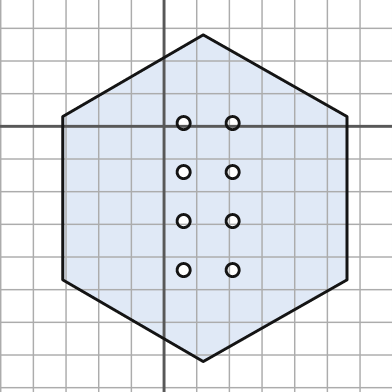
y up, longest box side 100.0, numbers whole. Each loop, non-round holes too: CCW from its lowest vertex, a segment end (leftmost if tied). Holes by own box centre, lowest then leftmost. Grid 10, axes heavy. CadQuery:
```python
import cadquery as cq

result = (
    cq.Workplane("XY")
    .moveTo(12.0, -72.0)
    .lineTo(56.0, -47.0)
    .lineTo(56.0, 3.0)
    .lineTo(12.0, 28.0)
    .lineTo(-31.0, 3.0)
    .lineTo(-31.0, -47.0)
    .close()
    .moveTo(6.0, -44.0)
    .circle(2.0)
    .moveTo(21.0, -44.0)
    .circle(2.0)
    .moveTo(6.0, -29.0)
    .circle(2.0)
    .moveTo(21.0, -29.0)
    .circle(2.0)
    .moveTo(6.0, -14.0)
    .circle(2.0)
    .moveTo(21.0, -14.0)
    .circle(2.0)
    .moveTo(6.0, 1.0)
    .circle(2.0)
    .moveTo(21.0, 1.0)
    .circle(2.0)
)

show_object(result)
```